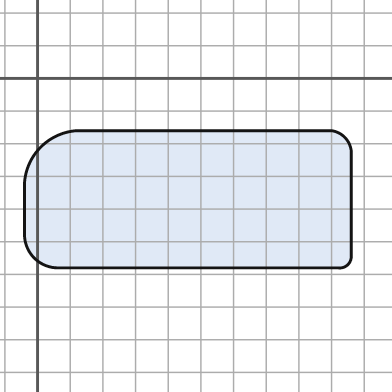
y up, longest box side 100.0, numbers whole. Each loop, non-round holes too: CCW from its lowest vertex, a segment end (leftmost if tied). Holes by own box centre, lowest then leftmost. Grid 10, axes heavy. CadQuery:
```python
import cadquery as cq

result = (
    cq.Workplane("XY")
    .moveTo(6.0, -58.0)
    .lineTo(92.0, -58.0)
    .threePointArc((95.0, -57.0), (96.0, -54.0))
    .lineTo(96.0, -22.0)
    .threePointArc((94.0, -18.0), (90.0, -16.0))
    .lineTo(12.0, -16.0)
    .threePointArc((1.0, -21.0), (-4.0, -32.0))
    .lineTo(-4.0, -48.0)
    .threePointArc((-1.0, -55.0), (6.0, -58.0))
    .close()
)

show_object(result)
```